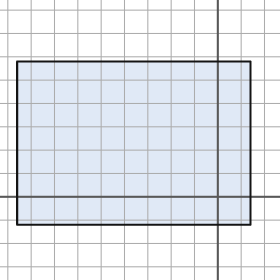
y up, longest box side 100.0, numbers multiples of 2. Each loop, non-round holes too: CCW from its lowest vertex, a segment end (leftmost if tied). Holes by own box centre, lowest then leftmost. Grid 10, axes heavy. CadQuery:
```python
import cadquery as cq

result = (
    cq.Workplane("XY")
    .moveTo(-86.0, -12.0)
    .lineTo(14.0, -12.0)
    .lineTo(14.0, 58.0)
    .lineTo(-86.0, 58.0)
    .close()
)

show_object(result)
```